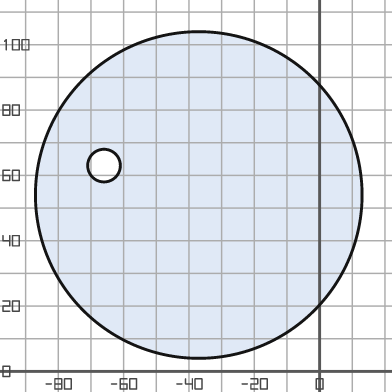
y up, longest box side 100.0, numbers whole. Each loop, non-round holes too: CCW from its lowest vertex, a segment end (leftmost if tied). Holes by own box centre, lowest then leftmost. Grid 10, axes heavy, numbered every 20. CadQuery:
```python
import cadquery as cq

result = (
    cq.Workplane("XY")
    .moveTo(-37.0, 54.0)
    .circle(50.0)
    .moveTo(-66.0, 63.0)
    .circle(5.0)
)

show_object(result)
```